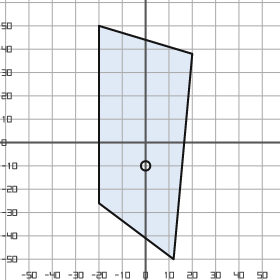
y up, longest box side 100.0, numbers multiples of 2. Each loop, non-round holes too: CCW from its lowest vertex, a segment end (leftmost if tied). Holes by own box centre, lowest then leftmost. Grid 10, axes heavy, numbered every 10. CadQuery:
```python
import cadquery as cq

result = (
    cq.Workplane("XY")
    .moveTo(12.0, -50.0)
    .lineTo(20.0, 38.0)
    .lineTo(-20.0, 50.0)
    .lineTo(-20.0, -26.0)
    .close()
    .moveTo(0.0, -10.0)
    .circle(2.0)
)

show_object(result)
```